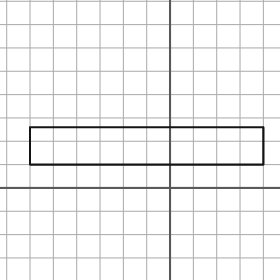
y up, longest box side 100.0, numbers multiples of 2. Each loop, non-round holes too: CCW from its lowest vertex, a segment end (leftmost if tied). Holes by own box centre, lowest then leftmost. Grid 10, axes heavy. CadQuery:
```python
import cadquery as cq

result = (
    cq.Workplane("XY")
    .moveTo(-60.0, 10.0)
    .lineTo(40.0, 10.0)
    .lineTo(40.0, 26.0)
    .lineTo(-60.0, 26.0)
    .close()
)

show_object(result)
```